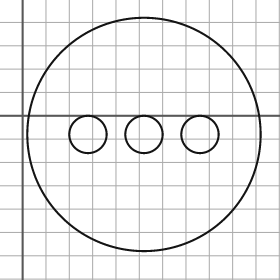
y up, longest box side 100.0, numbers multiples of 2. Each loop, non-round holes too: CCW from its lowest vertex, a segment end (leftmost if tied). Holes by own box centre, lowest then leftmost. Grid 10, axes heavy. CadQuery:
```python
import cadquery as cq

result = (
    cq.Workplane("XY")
    .moveTo(52.0, -8.0)
    .circle(50.0)
    .moveTo(28.0, -8.0)
    .circle(8.0)
    .moveTo(52.0, -8.0)
    .circle(8.0)
    .moveTo(76.0, -8.0)
    .circle(8.0)
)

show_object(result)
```